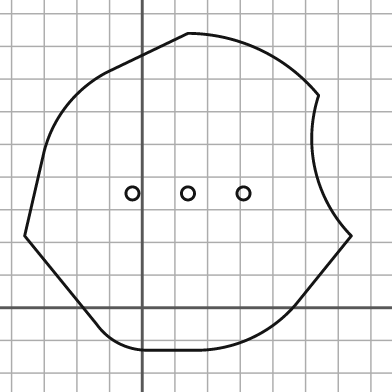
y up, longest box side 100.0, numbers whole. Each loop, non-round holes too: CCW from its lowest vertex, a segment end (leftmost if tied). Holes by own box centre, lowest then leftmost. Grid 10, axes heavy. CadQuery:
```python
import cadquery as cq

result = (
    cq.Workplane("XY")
    .moveTo(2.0, -13.0)
    .lineTo(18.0, -13.0)
    .threePointArc((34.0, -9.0), (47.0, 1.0))
    .lineTo(64.0, 22.0)
    .threePointArc((53.0, 42.0), (54.0, 65.0))
    .threePointArc((36.0, 79.0), (14.0, 84.0))
    .lineTo(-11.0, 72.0)
    .threePointArc((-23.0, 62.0), (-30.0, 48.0))
    .lineTo(-36.0, 22.0)
    .lineTo(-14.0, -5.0)
    .threePointArc((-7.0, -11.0), (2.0, -13.0))
    .close()
    .moveTo(-3.0, 35.0)
    .circle(2.0)
    .moveTo(14.0, 35.0)
    .circle(2.0)
    .moveTo(31.0, 35.0)
    .circle(2.0)
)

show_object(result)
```